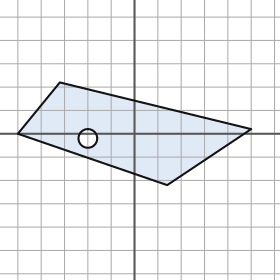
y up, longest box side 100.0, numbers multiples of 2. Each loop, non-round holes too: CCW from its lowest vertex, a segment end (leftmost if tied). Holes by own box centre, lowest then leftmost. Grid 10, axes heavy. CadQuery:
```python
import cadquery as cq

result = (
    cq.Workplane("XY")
    .moveTo(14.0, -22.0)
    .lineTo(50.0, 2.0)
    .lineTo(-32.0, 22.0)
    .lineTo(-50.0, 0.0)
    .close()
    .moveTo(-20.0, -2.0)
    .circle(4.0)
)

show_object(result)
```